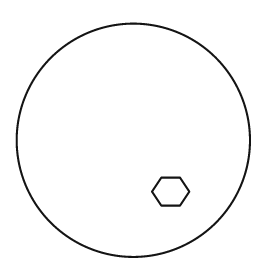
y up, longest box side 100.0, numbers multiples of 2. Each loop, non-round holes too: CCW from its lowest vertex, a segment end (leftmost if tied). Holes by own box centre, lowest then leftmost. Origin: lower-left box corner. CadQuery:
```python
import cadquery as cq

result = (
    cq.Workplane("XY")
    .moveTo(50.0, 50.0)
    .circle(50.0)
    .moveTo(62.0, 22.0)
    .lineTo(70.0, 22.0)
    .lineTo(74.0, 28.0)
    .lineTo(70.0, 34.0)
    .lineTo(62.0, 34.0)
    .lineTo(58.0, 28.0)
    .close()
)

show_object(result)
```